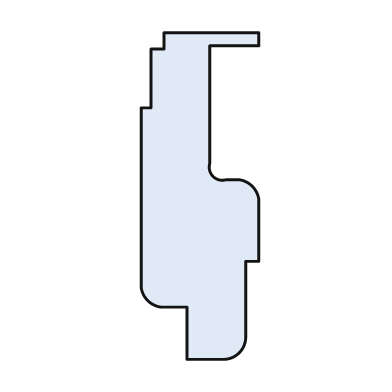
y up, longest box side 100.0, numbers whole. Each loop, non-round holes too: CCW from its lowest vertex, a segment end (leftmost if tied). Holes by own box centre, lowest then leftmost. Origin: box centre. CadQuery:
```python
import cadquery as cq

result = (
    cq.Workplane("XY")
    .moveTo(-4.0, -50.0)
    .lineTo(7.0, -50.0)
    .threePointArc((12.0, -48.0), (14.0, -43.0))
    .lineTo(14.0, -20.0)
    .lineTo(18.0, -20.0)
    .lineTo(18.0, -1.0)
    .threePointArc((16.0, 3.0), (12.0, 5.0))
    .lineTo(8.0, 5.0)
    .threePointArc((4.0, 6.0), (3.0, 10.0))
    .lineTo(3.0, 46.0)
    .lineTo(18.0, 46.0)
    .lineTo(18.0, 50.0)
    .lineTo(-11.0, 50.0)
    .lineTo(-11.0, 45.0)
    .lineTo(-15.0, 45.0)
    .lineTo(-15.0, 27.0)
    .lineTo(-18.0, 27.0)
    .lineTo(-18.0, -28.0)
    .threePointArc((-16.0, -32.0), (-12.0, -34.0))
    .lineTo(-4.0, -34.0)
    .close()
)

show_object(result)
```